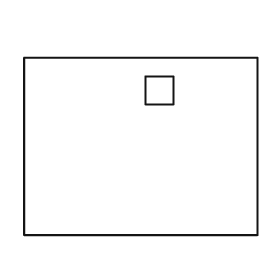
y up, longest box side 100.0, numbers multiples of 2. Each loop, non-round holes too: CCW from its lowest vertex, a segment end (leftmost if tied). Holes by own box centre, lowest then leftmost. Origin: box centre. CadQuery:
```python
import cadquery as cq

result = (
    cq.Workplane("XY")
    .moveTo(-50.0, -38.0)
    .lineTo(50.0, -38.0)
    .lineTo(50.0, 38.0)
    .lineTo(-50.0, 38.0)
    .close()
    .moveTo(2.0, 18.0)
    .lineTo(14.0, 18.0)
    .lineTo(14.0, 30.0)
    .lineTo(2.0, 30.0)
    .close()
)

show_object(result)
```